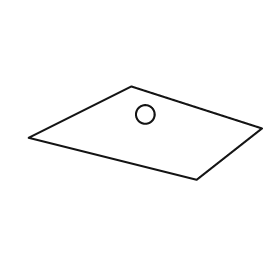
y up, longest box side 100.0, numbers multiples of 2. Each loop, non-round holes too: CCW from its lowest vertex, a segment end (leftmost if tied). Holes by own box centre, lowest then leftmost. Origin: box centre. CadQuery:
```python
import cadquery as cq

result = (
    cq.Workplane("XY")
    .moveTo(22.0, -20.0)
    .lineTo(50.0, 2.0)
    .lineTo(-6.0, 20.0)
    .lineTo(-50.0, -2.0)
    .close()
    .moveTo(0.0, 8.0)
    .circle(4.0)
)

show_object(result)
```